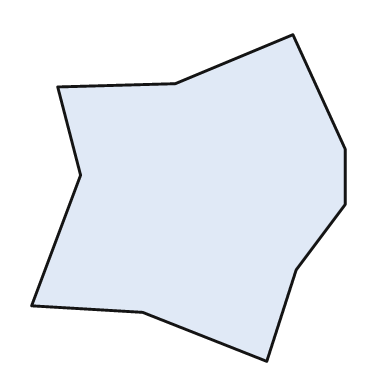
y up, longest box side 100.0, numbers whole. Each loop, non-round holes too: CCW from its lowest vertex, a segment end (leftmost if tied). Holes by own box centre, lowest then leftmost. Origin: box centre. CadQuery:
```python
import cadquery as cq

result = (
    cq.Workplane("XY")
    .moveTo(24.0, -50.0)
    .lineTo(33.0, -22.0)
    .lineTo(48.0, -2.0)
    .lineTo(48.0, 15.0)
    .lineTo(32.0, 50.0)
    .lineTo(-4.0, 35.0)
    .lineTo(-40.0, 34.0)
    .lineTo(-33.0, 7.0)
    .lineTo(-48.0, -33.0)
    .lineTo(-14.0, -35.0)
    .close()
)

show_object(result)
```